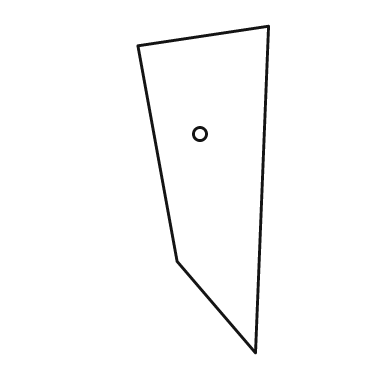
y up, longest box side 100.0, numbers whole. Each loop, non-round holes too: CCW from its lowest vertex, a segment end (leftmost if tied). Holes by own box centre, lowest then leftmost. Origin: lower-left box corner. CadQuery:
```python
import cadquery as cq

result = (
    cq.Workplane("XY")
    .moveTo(36.0, 0.0)
    .lineTo(40.0, 100.0)
    .lineTo(0.0, 94.0)
    .lineTo(12.0, 28.0)
    .close()
    .moveTo(19.0, 67.0)
    .circle(2.0)
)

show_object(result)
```